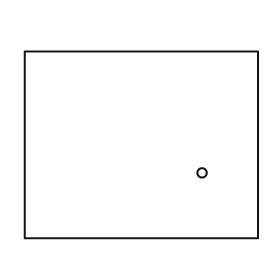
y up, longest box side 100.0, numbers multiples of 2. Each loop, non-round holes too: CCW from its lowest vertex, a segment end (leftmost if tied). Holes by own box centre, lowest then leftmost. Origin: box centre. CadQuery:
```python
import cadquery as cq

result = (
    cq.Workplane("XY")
    .moveTo(-50.0, -40.0)
    .lineTo(50.0, -40.0)
    .lineTo(50.0, 40.0)
    .lineTo(-50.0, 40.0)
    .close()
    .moveTo(26.0, -12.0)
    .circle(2.0)
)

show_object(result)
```